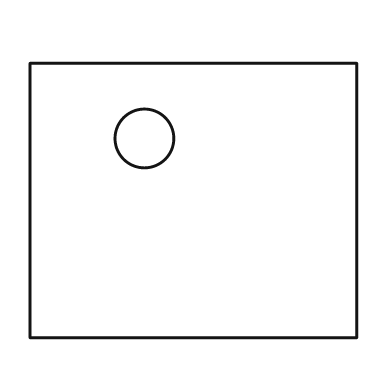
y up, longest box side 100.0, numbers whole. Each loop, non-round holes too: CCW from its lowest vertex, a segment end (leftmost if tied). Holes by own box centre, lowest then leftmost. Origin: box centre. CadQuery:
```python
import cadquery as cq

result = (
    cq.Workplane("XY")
    .moveTo(-50.0, -42.0)
    .lineTo(50.0, -42.0)
    .lineTo(50.0, 42.0)
    .lineTo(-50.0, 42.0)
    .close()
    .moveTo(-15.0, 19.0)
    .circle(9.0)
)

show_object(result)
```